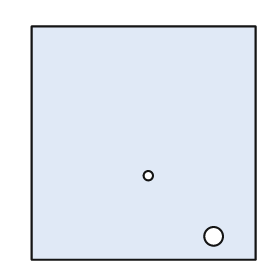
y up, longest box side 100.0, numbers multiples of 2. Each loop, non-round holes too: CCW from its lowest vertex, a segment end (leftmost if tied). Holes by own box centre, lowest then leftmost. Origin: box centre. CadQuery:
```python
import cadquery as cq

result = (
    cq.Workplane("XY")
    .moveTo(-48.0, -50.0)
    .lineTo(48.0, -50.0)
    .lineTo(48.0, 50.0)
    .lineTo(-48.0, 50.0)
    .close()
    .moveTo(30.0, -40.0)
    .circle(4.0)
    .moveTo(2.0, -14.0)
    .circle(2.0)
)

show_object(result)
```